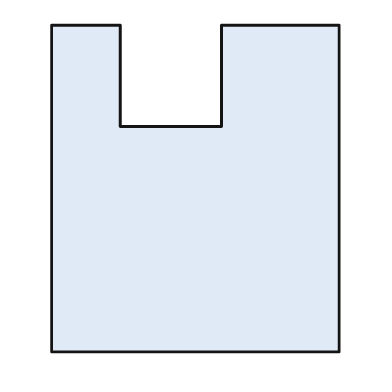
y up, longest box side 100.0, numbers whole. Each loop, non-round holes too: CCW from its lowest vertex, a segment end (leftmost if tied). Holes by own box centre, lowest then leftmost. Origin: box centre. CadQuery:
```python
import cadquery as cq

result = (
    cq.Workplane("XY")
    .moveTo(-44.0, -50.0)
    .lineTo(44.0, -50.0)
    .lineTo(44.0, 50.0)
    .lineTo(8.0, 50.0)
    .lineTo(8.0, 19.0)
    .lineTo(-23.0, 19.0)
    .lineTo(-23.0, 50.0)
    .lineTo(-44.0, 50.0)
    .close()
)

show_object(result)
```